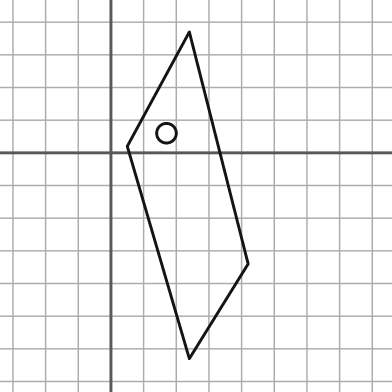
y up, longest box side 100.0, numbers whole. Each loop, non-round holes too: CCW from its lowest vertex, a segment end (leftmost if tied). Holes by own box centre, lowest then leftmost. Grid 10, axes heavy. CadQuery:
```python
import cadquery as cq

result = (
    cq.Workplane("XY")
    .moveTo(24.0, -63.0)
    .lineTo(42.0, -34.0)
    .lineTo(24.0, 37.0)
    .lineTo(5.0, 2.0)
    .close()
    .moveTo(17.0, 6.0)
    .circle(3.0)
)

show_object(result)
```